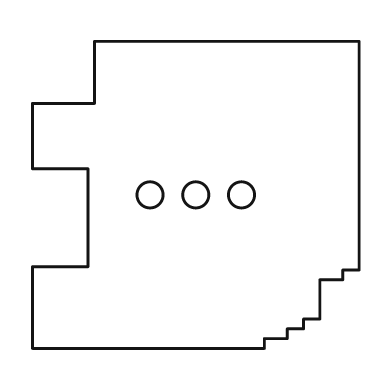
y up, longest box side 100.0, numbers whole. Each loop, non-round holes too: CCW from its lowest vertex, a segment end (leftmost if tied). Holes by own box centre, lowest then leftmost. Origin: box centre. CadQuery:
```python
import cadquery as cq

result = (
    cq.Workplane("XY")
    .moveTo(-50.0, -47.0)
    .lineTo(21.0, -47.0)
    .lineTo(21.0, -44.0)
    .lineTo(28.0, -44.0)
    .lineTo(28.0, -41.0)
    .lineTo(33.0, -41.0)
    .lineTo(33.0, -38.0)
    .lineTo(38.0, -38.0)
    .lineTo(38.0, -26.0)
    .lineTo(45.0, -26.0)
    .lineTo(45.0, -23.0)
    .lineTo(50.0, -23.0)
    .lineTo(50.0, 47.0)
    .lineTo(-31.0, 47.0)
    .lineTo(-31.0, 28.0)
    .lineTo(-50.0, 28.0)
    .lineTo(-50.0, 8.0)
    .lineTo(-33.0, 8.0)
    .lineTo(-33.0, -22.0)
    .lineTo(-50.0, -22.0)
    .close()
    .moveTo(-14.0, 0.0)
    .circle(4.0)
    .moveTo(0.0, 0.0)
    .circle(4.0)
    .moveTo(14.0, 0.0)
    .circle(4.0)
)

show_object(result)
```